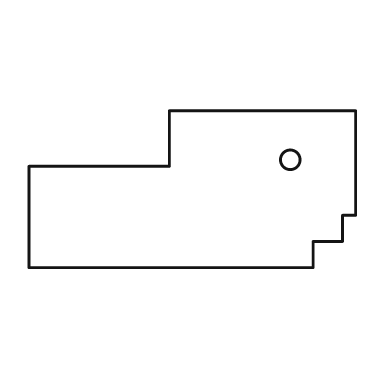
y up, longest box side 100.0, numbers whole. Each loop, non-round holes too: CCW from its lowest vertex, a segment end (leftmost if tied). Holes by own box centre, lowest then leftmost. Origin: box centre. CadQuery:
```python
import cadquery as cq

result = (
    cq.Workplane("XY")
    .moveTo(-50.0, -24.0)
    .lineTo(37.0, -24.0)
    .lineTo(37.0, -16.0)
    .lineTo(46.0, -16.0)
    .lineTo(46.0, -8.0)
    .lineTo(50.0, -8.0)
    .lineTo(50.0, 24.0)
    .lineTo(-7.0, 24.0)
    .lineTo(-7.0, 7.0)
    .lineTo(-50.0, 7.0)
    .close()
    .moveTo(30.0, 9.0)
    .circle(3.0)
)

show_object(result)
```